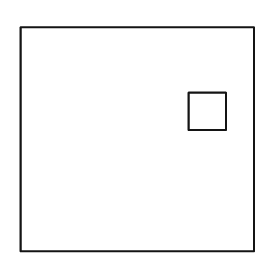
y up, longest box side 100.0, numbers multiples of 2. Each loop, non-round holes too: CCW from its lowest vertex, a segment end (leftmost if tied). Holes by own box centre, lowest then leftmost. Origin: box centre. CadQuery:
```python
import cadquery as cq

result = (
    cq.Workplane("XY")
    .moveTo(-50.0, -48.0)
    .lineTo(50.0, -48.0)
    .lineTo(50.0, 48.0)
    .lineTo(-50.0, 48.0)
    .close()
    .moveTo(22.0, 4.0)
    .lineTo(38.0, 4.0)
    .lineTo(38.0, 20.0)
    .lineTo(22.0, 20.0)
    .close()
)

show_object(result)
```